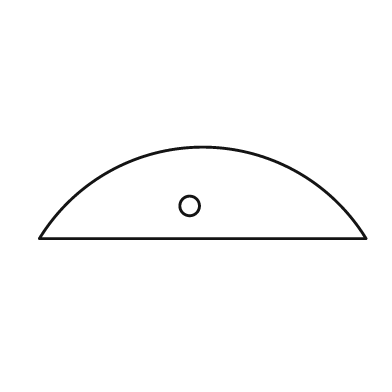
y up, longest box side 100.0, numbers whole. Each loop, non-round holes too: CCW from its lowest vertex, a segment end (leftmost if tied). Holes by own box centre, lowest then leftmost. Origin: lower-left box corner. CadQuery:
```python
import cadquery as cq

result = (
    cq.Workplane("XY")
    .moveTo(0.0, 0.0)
    .lineTo(100.0, 0.0)
    .threePointArc((50.0, 28.0), (0.0, 0.0))
    .close()
    .moveTo(46.0, 10.0)
    .circle(3.0)
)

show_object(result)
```